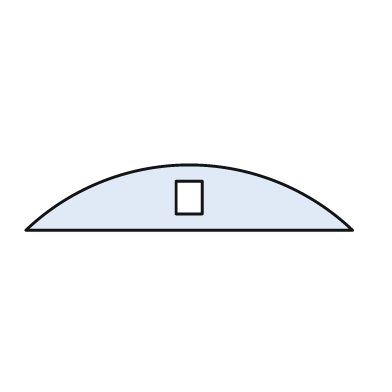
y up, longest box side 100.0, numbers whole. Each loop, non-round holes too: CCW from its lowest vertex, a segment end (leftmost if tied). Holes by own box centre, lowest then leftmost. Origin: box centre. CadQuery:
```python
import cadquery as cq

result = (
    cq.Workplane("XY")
    .moveTo(-50.0, -10.0)
    .lineTo(50.0, -10.0)
    .threePointArc((0.0, 10.0), (-50.0, -10.0))
    .close()
    .moveTo(-4.0, -5.0)
    .lineTo(4.0, -5.0)
    .lineTo(4.0, 5.0)
    .lineTo(-4.0, 5.0)
    .close()
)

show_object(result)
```